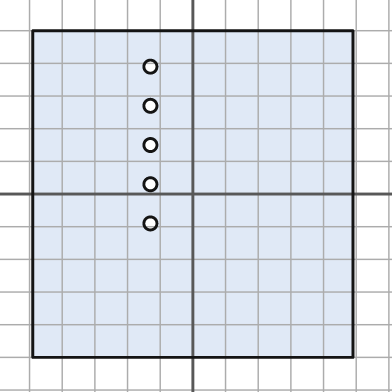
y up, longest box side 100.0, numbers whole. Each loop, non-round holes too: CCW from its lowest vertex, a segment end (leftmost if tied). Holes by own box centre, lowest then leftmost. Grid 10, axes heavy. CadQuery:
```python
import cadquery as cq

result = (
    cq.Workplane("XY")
    .moveTo(-49.0, -50.0)
    .lineTo(49.0, -50.0)
    .lineTo(49.0, 50.0)
    .lineTo(-49.0, 50.0)
    .close()
    .moveTo(-13.0, -9.0)
    .circle(2.0)
    .moveTo(-13.0, 3.0)
    .circle(2.0)
    .moveTo(-13.0, 15.0)
    .circle(2.0)
    .moveTo(-13.0, 27.0)
    .circle(2.0)
    .moveTo(-13.0, 39.0)
    .circle(2.0)
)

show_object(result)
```